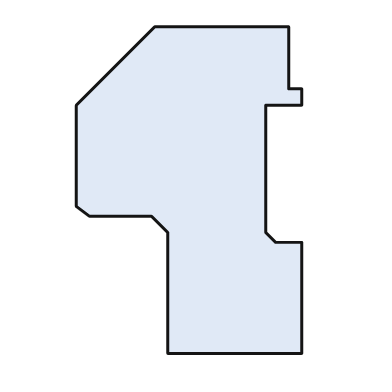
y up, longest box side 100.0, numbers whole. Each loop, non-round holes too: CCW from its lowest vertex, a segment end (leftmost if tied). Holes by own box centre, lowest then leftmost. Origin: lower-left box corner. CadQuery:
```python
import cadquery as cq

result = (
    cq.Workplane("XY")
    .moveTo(28.0, 0.0)
    .lineTo(69.0, 0.0)
    .lineTo(69.0, 34.0)
    .lineTo(61.0, 34.0)
    .lineTo(58.0, 37.0)
    .lineTo(58.0, 76.0)
    .lineTo(69.0, 76.0)
    .lineTo(69.0, 81.0)
    .lineTo(65.0, 81.0)
    .lineTo(65.0, 100.0)
    .lineTo(24.0, 100.0)
    .lineTo(0.0, 76.0)
    .lineTo(0.0, 45.0)
    .lineTo(4.0, 42.0)
    .lineTo(23.0, 42.0)
    .lineTo(28.0, 37.0)
    .close()
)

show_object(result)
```